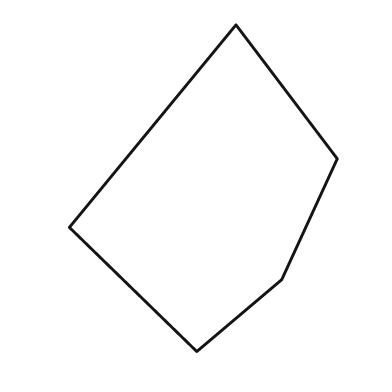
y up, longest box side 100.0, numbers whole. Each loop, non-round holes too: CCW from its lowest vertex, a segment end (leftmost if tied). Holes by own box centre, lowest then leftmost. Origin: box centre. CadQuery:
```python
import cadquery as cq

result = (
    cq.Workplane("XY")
    .moveTo(-2.0, -50.0)
    .lineTo(24.0, -28.0)
    .lineTo(41.0, 9.0)
    .lineTo(10.0, 50.0)
    .lineTo(-41.0, -12.0)
    .close()
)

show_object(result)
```